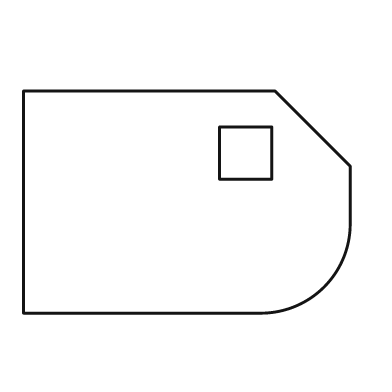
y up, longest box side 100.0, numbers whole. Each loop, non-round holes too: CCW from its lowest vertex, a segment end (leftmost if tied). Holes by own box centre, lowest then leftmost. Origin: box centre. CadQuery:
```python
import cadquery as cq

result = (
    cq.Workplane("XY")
    .moveTo(-50.0, -34.0)
    .lineTo(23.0, -34.0)
    .threePointArc((42.0, -26.0), (50.0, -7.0))
    .lineTo(50.0, 11.0)
    .lineTo(27.0, 34.0)
    .lineTo(-50.0, 34.0)
    .close()
    .moveTo(10.0, 7.0)
    .lineTo(26.0, 7.0)
    .lineTo(26.0, 23.0)
    .lineTo(10.0, 23.0)
    .close()
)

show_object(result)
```